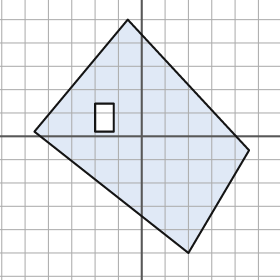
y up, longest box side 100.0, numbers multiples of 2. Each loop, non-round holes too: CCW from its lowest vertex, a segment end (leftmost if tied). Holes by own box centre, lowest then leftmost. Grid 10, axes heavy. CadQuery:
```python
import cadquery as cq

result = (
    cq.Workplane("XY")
    .moveTo(20.0, -50.0)
    .lineTo(46.0, -6.0)
    .lineTo(-6.0, 50.0)
    .lineTo(-46.0, 2.0)
    .close()
    .moveTo(-20.0, 2.0)
    .lineTo(-12.0, 2.0)
    .lineTo(-12.0, 14.0)
    .lineTo(-20.0, 14.0)
    .close()
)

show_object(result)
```